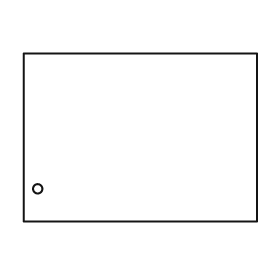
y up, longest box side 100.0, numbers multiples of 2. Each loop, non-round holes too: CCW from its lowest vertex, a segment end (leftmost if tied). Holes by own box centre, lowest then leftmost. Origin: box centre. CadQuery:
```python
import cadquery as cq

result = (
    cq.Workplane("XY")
    .moveTo(-50.0, -36.0)
    .lineTo(50.0, -36.0)
    .lineTo(50.0, 36.0)
    .lineTo(-50.0, 36.0)
    .close()
    .moveTo(-44.0, -22.0)
    .circle(2.0)
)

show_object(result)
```